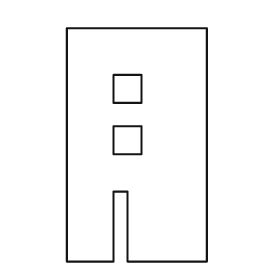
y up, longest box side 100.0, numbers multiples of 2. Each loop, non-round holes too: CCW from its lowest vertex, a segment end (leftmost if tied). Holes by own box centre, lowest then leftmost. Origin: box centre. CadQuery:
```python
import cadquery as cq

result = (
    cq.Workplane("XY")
    .moveTo(-30.0, -50.0)
    .lineTo(-10.0, -50.0)
    .lineTo(-10.0, -20.0)
    .lineTo(-4.0, -20.0)
    .lineTo(-4.0, -50.0)
    .lineTo(30.0, -50.0)
    .lineTo(30.0, 50.0)
    .lineTo(-30.0, 50.0)
    .close()
    .moveTo(-10.0, -4.0)
    .lineTo(2.0, -4.0)
    .lineTo(2.0, 8.0)
    .lineTo(-10.0, 8.0)
    .close()
    .moveTo(-10.0, 18.0)
    .lineTo(2.0, 18.0)
    .lineTo(2.0, 30.0)
    .lineTo(-10.0, 30.0)
    .close()
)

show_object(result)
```